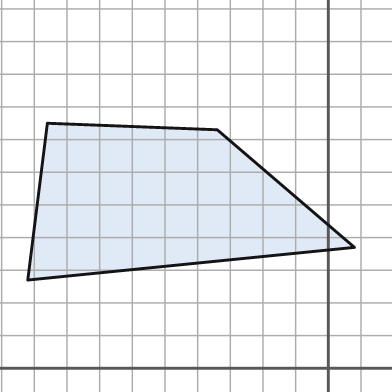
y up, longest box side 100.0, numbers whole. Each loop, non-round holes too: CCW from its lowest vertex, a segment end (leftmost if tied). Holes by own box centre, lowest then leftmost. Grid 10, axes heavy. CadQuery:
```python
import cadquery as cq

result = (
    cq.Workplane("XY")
    .moveTo(-92.0, 27.0)
    .lineTo(8.0, 37.0)
    .lineTo(-34.0, 73.0)
    .lineTo(-86.0, 75.0)
    .close()
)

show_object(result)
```